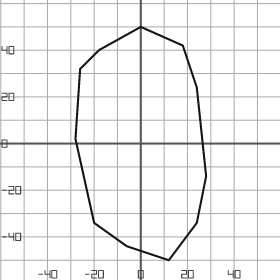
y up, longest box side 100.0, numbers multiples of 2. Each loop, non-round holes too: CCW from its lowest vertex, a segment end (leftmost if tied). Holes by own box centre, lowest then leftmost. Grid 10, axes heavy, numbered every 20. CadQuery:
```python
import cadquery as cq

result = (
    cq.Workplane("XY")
    .moveTo(12.0, -50.0)
    .lineTo(24.0, -34.0)
    .lineTo(28.0, -14.0)
    .lineTo(24.0, 24.0)
    .lineTo(18.0, 42.0)
    .lineTo(0.0, 50.0)
    .lineTo(-18.0, 40.0)
    .lineTo(-26.0, 32.0)
    .lineTo(-28.0, 2.0)
    .lineTo(-20.0, -34.0)
    .lineTo(-6.0, -44.0)
    .close()
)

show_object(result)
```